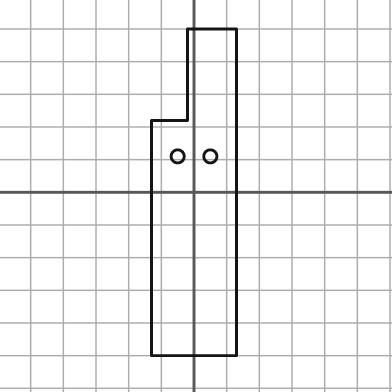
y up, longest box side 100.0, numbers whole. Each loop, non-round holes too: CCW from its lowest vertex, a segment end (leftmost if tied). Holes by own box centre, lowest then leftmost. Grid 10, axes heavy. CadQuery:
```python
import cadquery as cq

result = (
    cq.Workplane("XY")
    .moveTo(-13.0, -50.0)
    .lineTo(13.0, -50.0)
    .lineTo(13.0, 50.0)
    .lineTo(-2.0, 50.0)
    .lineTo(-2.0, 22.0)
    .lineTo(-13.0, 22.0)
    .close()
    .moveTo(-5.0, 11.0)
    .circle(2.0)
    .moveTo(5.0, 11.0)
    .circle(2.0)
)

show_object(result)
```